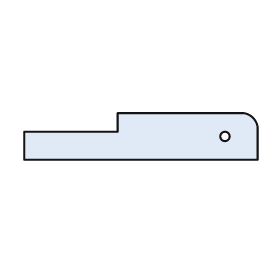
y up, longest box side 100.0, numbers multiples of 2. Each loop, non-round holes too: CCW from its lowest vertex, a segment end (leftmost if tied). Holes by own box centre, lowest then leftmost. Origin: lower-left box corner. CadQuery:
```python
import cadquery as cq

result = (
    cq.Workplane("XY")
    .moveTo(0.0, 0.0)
    .lineTo(100.0, 0.0)
    .lineTo(100.0, 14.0)
    .threePointArc((98.0, 18.0), (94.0, 20.0))
    .lineTo(40.0, 20.0)
    .lineTo(40.0, 12.0)
    .lineTo(0.0, 12.0)
    .close()
    .moveTo(86.0, 10.0)
    .circle(2.0)
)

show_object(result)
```